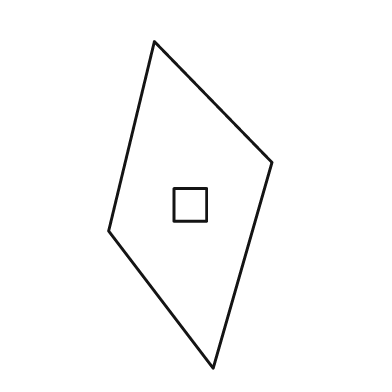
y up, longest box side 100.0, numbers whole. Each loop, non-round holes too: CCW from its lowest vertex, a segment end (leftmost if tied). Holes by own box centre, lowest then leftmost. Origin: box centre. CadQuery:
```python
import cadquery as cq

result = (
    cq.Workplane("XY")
    .moveTo(7.0, -50.0)
    .lineTo(25.0, 13.0)
    .lineTo(-11.0, 50.0)
    .lineTo(-25.0, -8.0)
    .close()
    .moveTo(-5.0, -5.0)
    .lineTo(5.0, -5.0)
    .lineTo(5.0, 5.0)
    .lineTo(-5.0, 5.0)
    .close()
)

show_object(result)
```